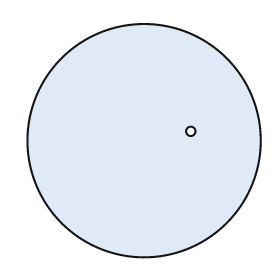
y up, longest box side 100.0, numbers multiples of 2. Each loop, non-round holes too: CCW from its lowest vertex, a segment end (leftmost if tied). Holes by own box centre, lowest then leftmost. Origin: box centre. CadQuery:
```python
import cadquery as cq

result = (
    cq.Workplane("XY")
    .moveTo(0.0, 0.0)
    .circle(50.0)
    .moveTo(20.0, 4.0)
    .circle(2.0)
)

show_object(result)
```